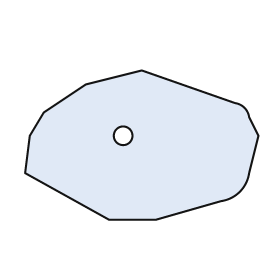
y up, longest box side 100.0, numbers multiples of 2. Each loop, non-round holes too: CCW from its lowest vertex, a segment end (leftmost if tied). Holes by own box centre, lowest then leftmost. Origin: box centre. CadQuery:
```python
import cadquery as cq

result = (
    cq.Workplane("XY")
    .moveTo(-14.0, -32.0)
    .lineTo(6.0, -32.0)
    .lineTo(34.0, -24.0)
    .threePointArc((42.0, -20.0), (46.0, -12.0))
    .lineTo(50.0, 4.0)
    .lineTo(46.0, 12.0)
    .threePointArc((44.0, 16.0), (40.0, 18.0))
    .lineTo(0.0, 32.0)
    .lineTo(-24.0, 26.0)
    .lineTo(-42.0, 14.0)
    .lineTo(-48.0, 4.0)
    .lineTo(-50.0, -12.0)
    .close()
    .moveTo(-8.0, 4.0)
    .circle(4.0)
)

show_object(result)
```